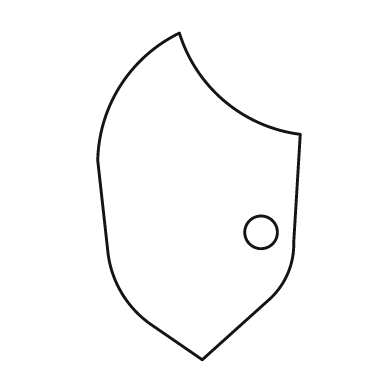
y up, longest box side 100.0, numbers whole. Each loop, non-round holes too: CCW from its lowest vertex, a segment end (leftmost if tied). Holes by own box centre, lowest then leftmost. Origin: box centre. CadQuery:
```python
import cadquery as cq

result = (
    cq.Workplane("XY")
    .moveTo(1.0, -50.0)
    .lineTo(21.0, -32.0)
    .threePointArc((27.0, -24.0), (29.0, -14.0))
    .lineTo(31.0, 19.0)
    .threePointArc((8.0, 29.0), (-6.0, 50.0))
    .threePointArc((-24.0, 34.0), (-31.0, 11.0))
    .lineTo(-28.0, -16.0)
    .threePointArc((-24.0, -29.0), (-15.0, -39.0))
    .close()
    .moveTo(19.0, -11.0)
    .circle(5.0)
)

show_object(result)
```